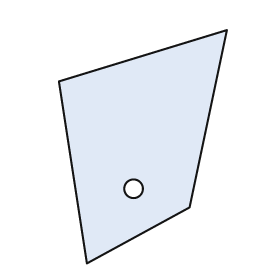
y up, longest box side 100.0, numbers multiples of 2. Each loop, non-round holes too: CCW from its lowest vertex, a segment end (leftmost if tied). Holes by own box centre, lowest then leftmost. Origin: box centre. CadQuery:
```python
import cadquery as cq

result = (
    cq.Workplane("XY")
    .moveTo(-24.0, -50.0)
    .lineTo(20.0, -26.0)
    .lineTo(36.0, 50.0)
    .lineTo(-36.0, 28.0)
    .close()
    .moveTo(-4.0, -18.0)
    .circle(4.0)
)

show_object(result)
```